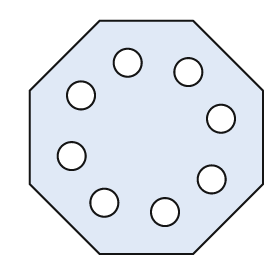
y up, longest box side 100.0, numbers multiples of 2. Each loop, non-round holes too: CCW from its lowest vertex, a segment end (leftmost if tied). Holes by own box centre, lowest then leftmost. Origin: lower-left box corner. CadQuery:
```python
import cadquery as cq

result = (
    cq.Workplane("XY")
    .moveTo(30.0, 0.0)
    .lineTo(70.0, 0.0)
    .lineTo(100.0, 30.0)
    .lineTo(100.0, 70.0)
    .lineTo(70.0, 100.0)
    .lineTo(30.0, 100.0)
    .lineTo(0.0, 70.0)
    .lineTo(0.0, 30.0)
    .close()
    .moveTo(58.0, 18.0)
    .circle(6.0)
    .moveTo(32.0, 22.0)
    .circle(6.0)
    .moveTo(78.0, 32.0)
    .circle(6.0)
    .moveTo(18.0, 42.0)
    .circle(6.0)
    .moveTo(82.0, 58.0)
    .circle(6.0)
    .moveTo(22.0, 68.0)
    .circle(6.0)
    .moveTo(68.0, 78.0)
    .circle(6.0)
    .moveTo(42.0, 82.0)
    .circle(6.0)
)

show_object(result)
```